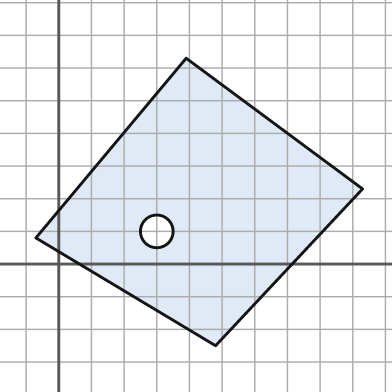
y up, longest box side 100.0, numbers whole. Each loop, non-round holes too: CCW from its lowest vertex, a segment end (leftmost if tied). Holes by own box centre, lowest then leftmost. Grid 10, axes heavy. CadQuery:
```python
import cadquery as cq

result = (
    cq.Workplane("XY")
    .moveTo(48.0, -25.0)
    .lineTo(93.0, 23.0)
    .lineTo(39.0, 63.0)
    .lineTo(-7.0, 8.0)
    .close()
    .moveTo(30.0, 10.0)
    .circle(5.0)
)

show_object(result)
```